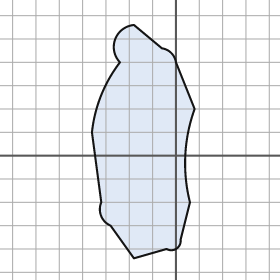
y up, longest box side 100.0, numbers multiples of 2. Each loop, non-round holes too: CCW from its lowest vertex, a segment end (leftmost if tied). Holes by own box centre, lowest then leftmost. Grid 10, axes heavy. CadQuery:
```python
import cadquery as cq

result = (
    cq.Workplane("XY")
    .moveTo(-18.0, -44.0)
    .lineTo(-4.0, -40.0)
    .threePointArc((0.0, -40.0), (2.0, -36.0))
    .lineTo(6.0, -20.0)
    .threePointArc((4.0, 0.0), (8.0, 20.0))
    .lineTo(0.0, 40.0)
    .threePointArc((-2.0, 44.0), (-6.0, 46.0))
    .lineTo(-18.0, 56.0)
    .threePointArc((-26.0, 50.0), (-24.0, 40.0))
    .threePointArc((-32.0, 26.0), (-36.0, 10.0))
    .lineTo(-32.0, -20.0)
    .threePointArc((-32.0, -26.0), (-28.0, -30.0))
    .close()
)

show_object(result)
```